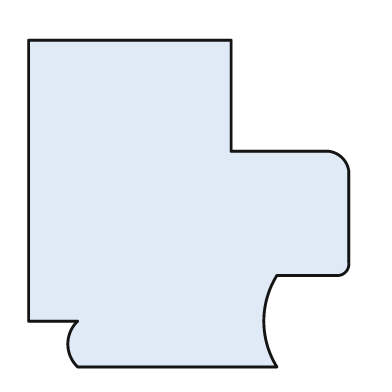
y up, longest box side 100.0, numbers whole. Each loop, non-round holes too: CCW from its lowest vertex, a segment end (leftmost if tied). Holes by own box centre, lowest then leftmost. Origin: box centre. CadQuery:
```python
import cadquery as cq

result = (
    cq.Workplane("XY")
    .moveTo(-34.0, -50.0)
    .lineTo(27.0, -50.0)
    .threePointArc((23.0, -36.0), (27.0, -22.0))
    .lineTo(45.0, -22.0)
    .threePointArc((48.0, -21.0), (49.0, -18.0))
    .lineTo(49.0, 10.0)
    .threePointArc((47.0, 14.0), (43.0, 16.0))
    .lineTo(13.0, 16.0)
    .lineTo(13.0, 50.0)
    .lineTo(-49.0, 50.0)
    .lineTo(-49.0, -36.0)
    .lineTo(-34.0, -36.0)
    .threePointArc((-37.0, -43.0), (-34.0, -50.0))
    .close()
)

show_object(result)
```